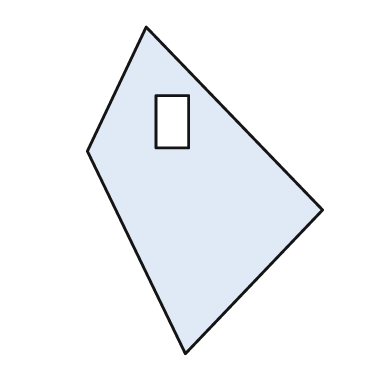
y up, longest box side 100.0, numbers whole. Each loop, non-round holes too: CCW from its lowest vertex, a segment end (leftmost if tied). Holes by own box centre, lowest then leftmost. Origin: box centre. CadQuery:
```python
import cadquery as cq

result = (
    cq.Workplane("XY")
    .moveTo(-6.0, -50.0)
    .lineTo(36.0, -6.0)
    .lineTo(-18.0, 50.0)
    .lineTo(-36.0, 12.0)
    .close()
    .moveTo(-15.0, 13.0)
    .lineTo(-5.0, 13.0)
    .lineTo(-5.0, 29.0)
    .lineTo(-15.0, 29.0)
    .close()
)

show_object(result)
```